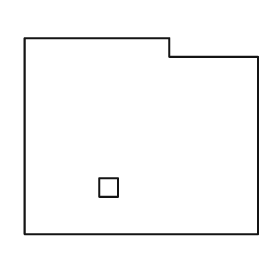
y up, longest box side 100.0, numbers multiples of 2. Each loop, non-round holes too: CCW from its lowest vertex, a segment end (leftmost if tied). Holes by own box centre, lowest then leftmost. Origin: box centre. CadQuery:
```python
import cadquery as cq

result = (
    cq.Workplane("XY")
    .moveTo(-50.0, -42.0)
    .lineTo(50.0, -42.0)
    .lineTo(50.0, 34.0)
    .lineTo(12.0, 34.0)
    .lineTo(12.0, 42.0)
    .lineTo(-50.0, 42.0)
    .close()
    .moveTo(-18.0, -26.0)
    .lineTo(-10.0, -26.0)
    .lineTo(-10.0, -18.0)
    .lineTo(-18.0, -18.0)
    .close()
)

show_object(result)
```